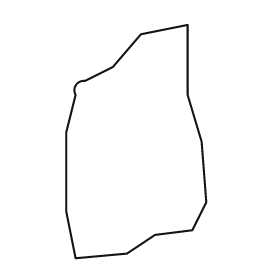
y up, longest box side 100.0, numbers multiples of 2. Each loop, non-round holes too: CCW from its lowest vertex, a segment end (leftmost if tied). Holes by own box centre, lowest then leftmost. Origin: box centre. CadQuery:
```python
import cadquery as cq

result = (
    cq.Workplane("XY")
    .moveTo(-26.0, -50.0)
    .lineTo(-4.0, -48.0)
    .lineTo(8.0, -40.0)
    .lineTo(24.0, -38.0)
    .lineTo(30.0, -26.0)
    .lineTo(28.0, 0.0)
    .lineTo(22.0, 20.0)
    .lineTo(22.0, 50.0)
    .lineTo(2.0, 46.0)
    .lineTo(-10.0, 32.0)
    .lineTo(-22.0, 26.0)
    .threePointArc((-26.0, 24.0), (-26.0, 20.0))
    .lineTo(-30.0, 4.0)
    .lineTo(-30.0, -30.0)
    .close()
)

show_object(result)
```